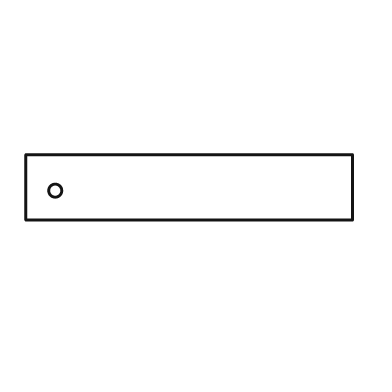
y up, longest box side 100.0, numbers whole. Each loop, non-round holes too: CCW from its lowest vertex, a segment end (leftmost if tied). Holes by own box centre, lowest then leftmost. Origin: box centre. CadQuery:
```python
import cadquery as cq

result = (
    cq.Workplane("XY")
    .moveTo(-50.0, -10.0)
    .lineTo(50.0, -10.0)
    .lineTo(50.0, 10.0)
    .lineTo(-50.0, 10.0)
    .close()
    .moveTo(-41.0, -1.0)
    .circle(2.0)
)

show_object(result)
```